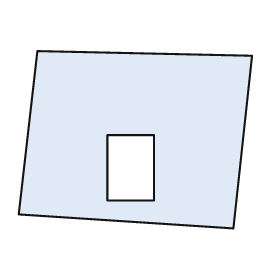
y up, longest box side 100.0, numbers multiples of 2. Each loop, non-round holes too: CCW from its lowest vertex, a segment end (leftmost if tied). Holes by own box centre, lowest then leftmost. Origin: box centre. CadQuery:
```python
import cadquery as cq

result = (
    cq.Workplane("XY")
    .moveTo(42.0, -38.0)
    .lineTo(50.0, 36.0)
    .lineTo(-42.0, 38.0)
    .lineTo(-50.0, -32.0)
    .close()
    .moveTo(-12.0, -26.0)
    .lineTo(8.0, -26.0)
    .lineTo(8.0, 2.0)
    .lineTo(-12.0, 2.0)
    .close()
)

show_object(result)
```